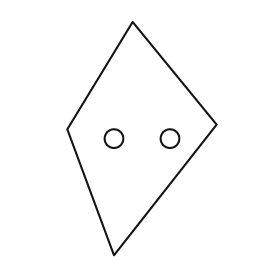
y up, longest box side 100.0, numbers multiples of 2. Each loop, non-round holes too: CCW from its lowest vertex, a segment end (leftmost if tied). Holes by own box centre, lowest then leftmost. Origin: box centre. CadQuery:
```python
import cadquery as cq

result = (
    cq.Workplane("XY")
    .moveTo(-12.0, -50.0)
    .lineTo(32.0, 6.0)
    .lineTo(-4.0, 50.0)
    .lineTo(-32.0, 4.0)
    .close()
    .moveTo(-12.0, 0.0)
    .circle(4.0)
    .moveTo(12.0, 0.0)
    .circle(4.0)
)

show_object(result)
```